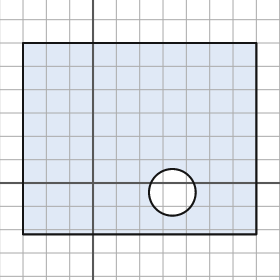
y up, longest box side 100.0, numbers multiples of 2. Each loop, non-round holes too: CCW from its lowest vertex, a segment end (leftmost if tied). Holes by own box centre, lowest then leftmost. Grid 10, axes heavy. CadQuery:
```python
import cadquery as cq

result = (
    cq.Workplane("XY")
    .moveTo(-30.0, -22.0)
    .lineTo(70.0, -22.0)
    .lineTo(70.0, 60.0)
    .lineTo(-30.0, 60.0)
    .close()
    .moveTo(34.0, -4.0)
    .circle(10.0)
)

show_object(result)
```